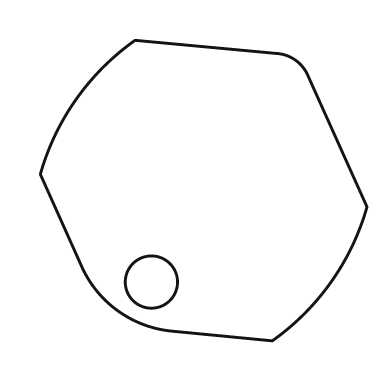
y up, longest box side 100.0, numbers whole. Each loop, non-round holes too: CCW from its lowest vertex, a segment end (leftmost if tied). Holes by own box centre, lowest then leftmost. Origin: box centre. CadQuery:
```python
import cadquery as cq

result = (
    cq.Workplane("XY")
    .moveTo(21.0, -46.0)
    .threePointArc((39.0, -28.0), (50.0, -5.0))
    .lineTo(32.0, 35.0)
    .threePointArc((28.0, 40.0), (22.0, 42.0))
    .lineTo(-21.0, 46.0)
    .threePointArc((-39.0, 28.0), (-50.0, 5.0))
    .lineTo(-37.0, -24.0)
    .threePointArc((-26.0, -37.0), (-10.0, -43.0))
    .close()
    .moveTo(-16.0, -28.0)
    .circle(8.0)
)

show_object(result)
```